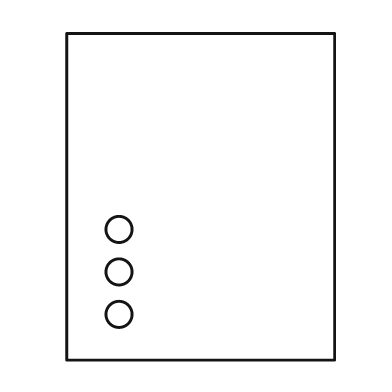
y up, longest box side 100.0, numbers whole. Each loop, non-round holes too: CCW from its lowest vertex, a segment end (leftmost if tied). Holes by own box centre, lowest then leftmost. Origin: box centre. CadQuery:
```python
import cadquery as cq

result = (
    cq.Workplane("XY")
    .moveTo(-41.0, -50.0)
    .lineTo(41.0, -50.0)
    .lineTo(41.0, 50.0)
    .lineTo(-41.0, 50.0)
    .close()
    .moveTo(-25.0, -36.0)
    .circle(4.0)
    .moveTo(-25.0, -23.0)
    .circle(4.0)
    .moveTo(-25.0, -10.0)
    .circle(4.0)
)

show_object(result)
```